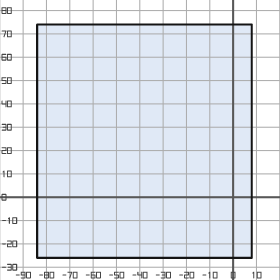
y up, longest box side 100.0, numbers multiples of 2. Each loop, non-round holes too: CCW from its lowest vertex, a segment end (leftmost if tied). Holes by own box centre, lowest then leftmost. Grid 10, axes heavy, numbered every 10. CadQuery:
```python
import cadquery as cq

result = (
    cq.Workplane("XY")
    .moveTo(-84.0, -26.0)
    .lineTo(8.0, -26.0)
    .lineTo(8.0, 74.0)
    .lineTo(-84.0, 74.0)
    .close()
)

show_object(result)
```